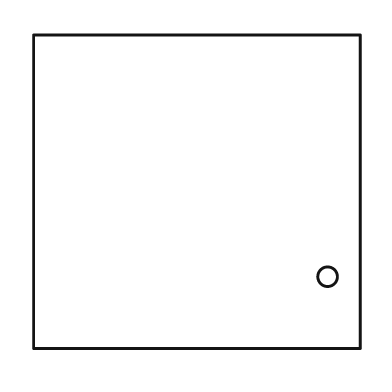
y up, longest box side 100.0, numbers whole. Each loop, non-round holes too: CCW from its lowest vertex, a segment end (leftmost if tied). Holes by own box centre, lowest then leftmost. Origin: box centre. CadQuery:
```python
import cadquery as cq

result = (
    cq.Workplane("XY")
    .moveTo(-50.0, -48.0)
    .lineTo(50.0, -48.0)
    .lineTo(50.0, 48.0)
    .lineTo(-50.0, 48.0)
    .close()
    .moveTo(40.0, -26.0)
    .circle(3.0)
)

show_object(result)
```